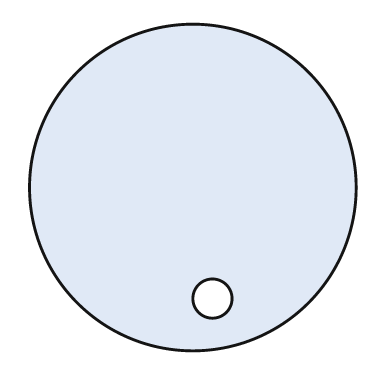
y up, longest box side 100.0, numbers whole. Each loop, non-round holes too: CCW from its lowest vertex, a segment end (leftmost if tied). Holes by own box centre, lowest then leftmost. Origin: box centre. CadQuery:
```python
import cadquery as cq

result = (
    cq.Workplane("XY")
    .moveTo(0.0, 0.0)
    .circle(50.0)
    .moveTo(6.0, -34.0)
    .circle(6.0)
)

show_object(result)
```